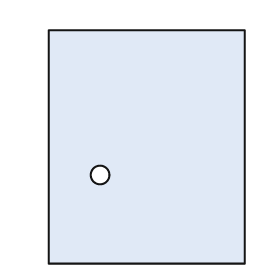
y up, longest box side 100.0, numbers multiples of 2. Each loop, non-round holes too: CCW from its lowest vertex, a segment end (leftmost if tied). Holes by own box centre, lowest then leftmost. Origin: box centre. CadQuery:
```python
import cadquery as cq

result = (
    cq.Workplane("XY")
    .moveTo(-42.0, -50.0)
    .lineTo(42.0, -50.0)
    .lineTo(42.0, 50.0)
    .lineTo(-42.0, 50.0)
    .close()
    .moveTo(-20.0, -12.0)
    .circle(4.0)
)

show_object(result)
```